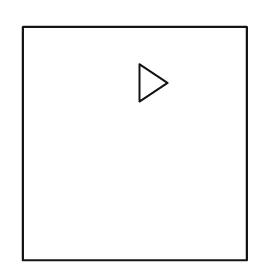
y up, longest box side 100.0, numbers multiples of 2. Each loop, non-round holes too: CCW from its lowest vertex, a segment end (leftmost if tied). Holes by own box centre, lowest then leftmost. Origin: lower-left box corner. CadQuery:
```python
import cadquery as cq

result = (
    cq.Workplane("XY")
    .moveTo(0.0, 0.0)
    .lineTo(96.0, 0.0)
    .lineTo(96.0, 100.0)
    .lineTo(0.0, 100.0)
    .close()
    .moveTo(50.0, 68.0)
    .lineTo(62.0, 76.0)
    .lineTo(50.0, 84.0)
    .close()
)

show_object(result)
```